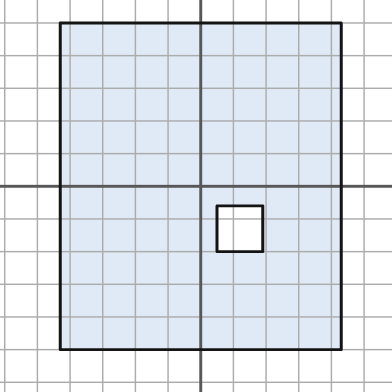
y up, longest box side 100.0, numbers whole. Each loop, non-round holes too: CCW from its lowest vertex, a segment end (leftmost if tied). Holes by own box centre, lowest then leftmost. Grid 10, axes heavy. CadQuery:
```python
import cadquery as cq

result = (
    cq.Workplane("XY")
    .moveTo(-43.0, -50.0)
    .lineTo(43.0, -50.0)
    .lineTo(43.0, 50.0)
    .lineTo(-43.0, 50.0)
    .close()
    .moveTo(5.0, -20.0)
    .lineTo(19.0, -20.0)
    .lineTo(19.0, -6.0)
    .lineTo(5.0, -6.0)
    .close()
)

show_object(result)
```